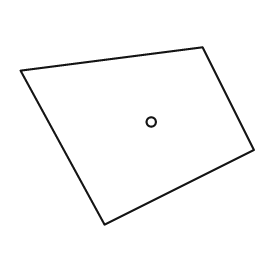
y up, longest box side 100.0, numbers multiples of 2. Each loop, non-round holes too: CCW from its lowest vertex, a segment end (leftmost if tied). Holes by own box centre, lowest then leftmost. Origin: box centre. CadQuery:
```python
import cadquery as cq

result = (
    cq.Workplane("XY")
    .moveTo(-14.0, -38.0)
    .lineTo(50.0, -6.0)
    .lineTo(28.0, 38.0)
    .lineTo(-50.0, 28.0)
    .close()
    .moveTo(6.0, 6.0)
    .circle(2.0)
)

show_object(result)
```